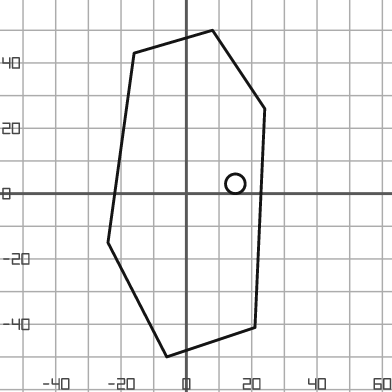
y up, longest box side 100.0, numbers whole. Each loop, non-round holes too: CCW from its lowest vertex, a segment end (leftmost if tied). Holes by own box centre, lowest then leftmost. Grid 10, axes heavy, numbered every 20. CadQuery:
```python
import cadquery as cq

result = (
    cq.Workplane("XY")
    .moveTo(-6.0, -50.0)
    .lineTo(21.0, -41.0)
    .lineTo(24.0, 26.0)
    .lineTo(8.0, 50.0)
    .lineTo(-16.0, 43.0)
    .lineTo(-24.0, -15.0)
    .close()
    .moveTo(15.0, 3.0)
    .circle(3.0)
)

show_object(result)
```